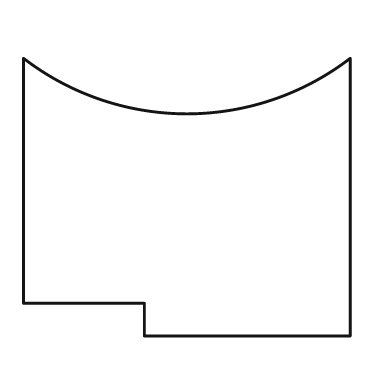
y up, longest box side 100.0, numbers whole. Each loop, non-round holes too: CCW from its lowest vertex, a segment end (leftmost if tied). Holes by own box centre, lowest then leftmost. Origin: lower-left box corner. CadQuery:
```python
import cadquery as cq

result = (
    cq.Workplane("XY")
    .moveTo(37.0, 0.0)
    .lineTo(100.0, 0.0)
    .lineTo(100.0, 85.0)
    .threePointArc((50.0, 68.0), (0.0, 85.0))
    .lineTo(0.0, 10.0)
    .lineTo(37.0, 10.0)
    .close()
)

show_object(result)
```